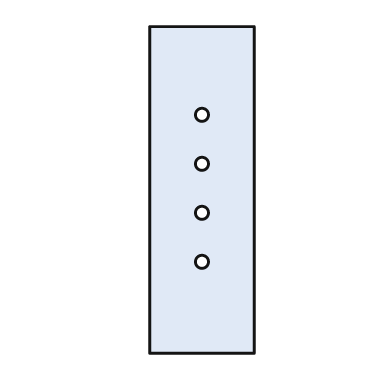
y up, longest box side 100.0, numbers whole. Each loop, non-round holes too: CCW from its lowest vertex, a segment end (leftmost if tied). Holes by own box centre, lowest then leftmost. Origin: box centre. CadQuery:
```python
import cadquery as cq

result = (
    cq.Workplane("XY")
    .moveTo(-16.0, -50.0)
    .lineTo(16.0, -50.0)
    .lineTo(16.0, 50.0)
    .lineTo(-16.0, 50.0)
    .close()
    .moveTo(0.0, -22.0)
    .circle(2.0)
    .moveTo(0.0, -7.0)
    .circle(2.0)
    .moveTo(0.0, 8.0)
    .circle(2.0)
    .moveTo(0.0, 23.0)
    .circle(2.0)
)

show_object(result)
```